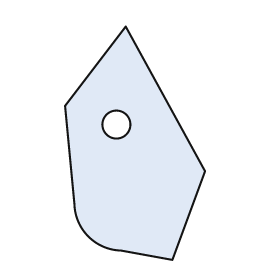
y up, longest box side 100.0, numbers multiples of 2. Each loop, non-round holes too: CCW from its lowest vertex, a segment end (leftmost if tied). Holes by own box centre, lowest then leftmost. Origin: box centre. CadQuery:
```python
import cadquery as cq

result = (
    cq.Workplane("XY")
    .moveTo(16.0, -50.0)
    .lineTo(30.0, -12.0)
    .lineTo(-4.0, 50.0)
    .lineTo(-30.0, 16.0)
    .lineTo(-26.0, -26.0)
    .threePointArc((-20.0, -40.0), (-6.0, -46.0))
    .close()
    .moveTo(-8.0, 8.0)
    .circle(6.0)
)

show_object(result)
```